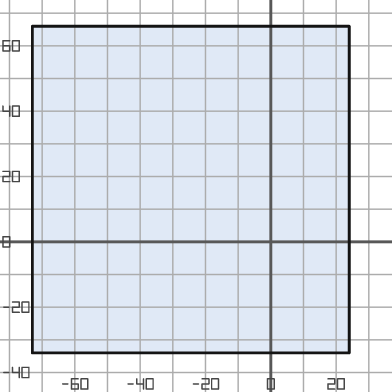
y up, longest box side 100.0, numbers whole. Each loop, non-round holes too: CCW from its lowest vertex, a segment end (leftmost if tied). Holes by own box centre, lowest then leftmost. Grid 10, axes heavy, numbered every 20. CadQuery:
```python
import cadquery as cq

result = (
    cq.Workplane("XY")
    .moveTo(-73.0, -34.0)
    .lineTo(24.0, -34.0)
    .lineTo(24.0, 66.0)
    .lineTo(-73.0, 66.0)
    .close()
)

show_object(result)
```